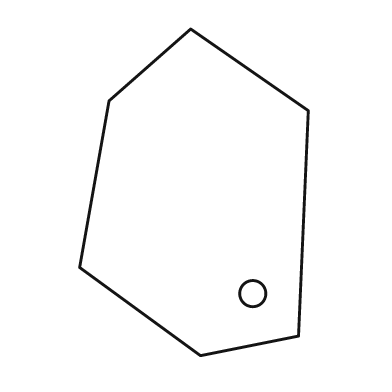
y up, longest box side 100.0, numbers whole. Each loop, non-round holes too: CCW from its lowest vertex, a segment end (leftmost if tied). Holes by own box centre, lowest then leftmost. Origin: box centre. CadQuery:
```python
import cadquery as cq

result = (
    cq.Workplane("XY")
    .moveTo(2.0, -50.0)
    .lineTo(32.0, -44.0)
    .lineTo(35.0, 25.0)
    .lineTo(-1.0, 50.0)
    .lineTo(-26.0, 28.0)
    .lineTo(-35.0, -23.0)
    .close()
    .moveTo(18.0, -31.0)
    .circle(4.0)
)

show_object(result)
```